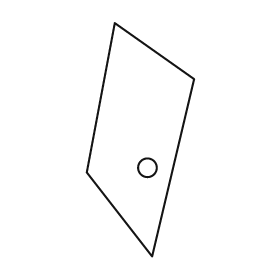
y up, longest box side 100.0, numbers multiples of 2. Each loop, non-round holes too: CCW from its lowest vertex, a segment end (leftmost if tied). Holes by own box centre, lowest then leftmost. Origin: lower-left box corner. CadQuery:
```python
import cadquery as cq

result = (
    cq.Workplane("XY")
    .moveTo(28.0, 0.0)
    .lineTo(46.0, 76.0)
    .lineTo(12.0, 100.0)
    .lineTo(0.0, 36.0)
    .close()
    .moveTo(26.0, 38.0)
    .circle(4.0)
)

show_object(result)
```